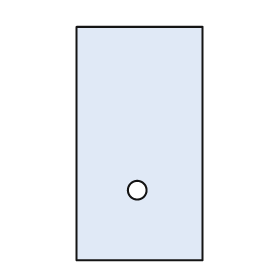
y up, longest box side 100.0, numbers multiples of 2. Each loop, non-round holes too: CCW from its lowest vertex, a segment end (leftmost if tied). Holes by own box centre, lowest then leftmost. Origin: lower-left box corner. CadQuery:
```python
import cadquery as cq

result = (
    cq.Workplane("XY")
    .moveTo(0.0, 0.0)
    .lineTo(54.0, 0.0)
    .lineTo(54.0, 100.0)
    .lineTo(0.0, 100.0)
    .close()
    .moveTo(26.0, 30.0)
    .circle(4.0)
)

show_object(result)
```